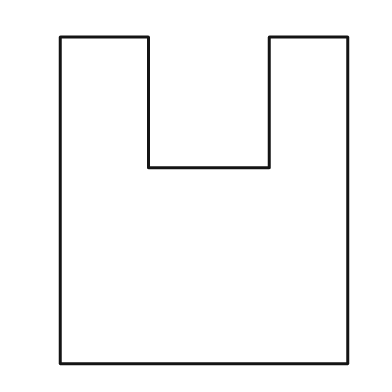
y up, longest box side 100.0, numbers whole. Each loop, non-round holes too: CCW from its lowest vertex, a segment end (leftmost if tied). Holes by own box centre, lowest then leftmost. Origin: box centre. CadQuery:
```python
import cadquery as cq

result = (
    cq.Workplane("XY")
    .moveTo(-44.0, -50.0)
    .lineTo(44.0, -50.0)
    .lineTo(44.0, 50.0)
    .lineTo(20.0, 50.0)
    .lineTo(20.0, 10.0)
    .lineTo(-17.0, 10.0)
    .lineTo(-17.0, 50.0)
    .lineTo(-44.0, 50.0)
    .close()
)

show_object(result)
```